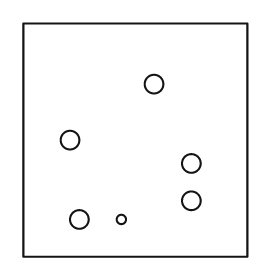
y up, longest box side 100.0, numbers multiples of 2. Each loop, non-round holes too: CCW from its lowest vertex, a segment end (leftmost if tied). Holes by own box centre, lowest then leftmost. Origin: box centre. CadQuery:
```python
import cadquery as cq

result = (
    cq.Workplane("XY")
    .moveTo(-48.0, -50.0)
    .lineTo(48.0, -50.0)
    .lineTo(48.0, 50.0)
    .lineTo(-48.0, 50.0)
    .close()
    .moveTo(-24.0, -34.0)
    .circle(4.0)
    .moveTo(-6.0, -34.0)
    .circle(2.0)
    .moveTo(24.0, -26.0)
    .circle(4.0)
    .moveTo(24.0, -10.0)
    .circle(4.0)
    .moveTo(-28.0, 0.0)
    .circle(4.0)
    .moveTo(8.0, 24.0)
    .circle(4.0)
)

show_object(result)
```